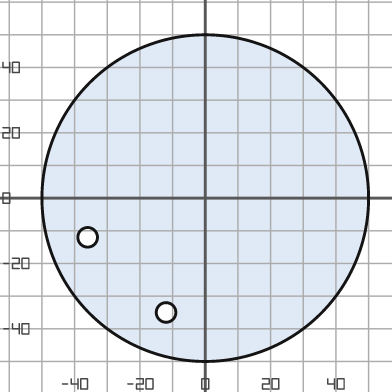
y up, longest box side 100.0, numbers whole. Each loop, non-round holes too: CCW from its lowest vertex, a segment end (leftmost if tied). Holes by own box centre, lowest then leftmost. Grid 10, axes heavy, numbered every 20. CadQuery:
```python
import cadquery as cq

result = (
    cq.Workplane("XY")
    .moveTo(0.0, 0.0)
    .circle(50.0)
    .moveTo(-12.0, -35.0)
    .circle(3.0)
    .moveTo(-36.0, -12.0)
    .circle(3.0)
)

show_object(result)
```